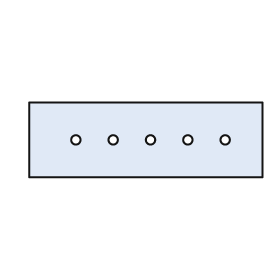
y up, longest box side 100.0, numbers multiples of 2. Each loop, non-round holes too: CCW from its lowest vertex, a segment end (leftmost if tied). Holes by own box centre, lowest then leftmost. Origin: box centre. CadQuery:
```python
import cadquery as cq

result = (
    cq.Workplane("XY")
    .moveTo(-50.0, -16.0)
    .lineTo(50.0, -16.0)
    .lineTo(50.0, 16.0)
    .lineTo(-50.0, 16.0)
    .close()
    .moveTo(-30.0, 0.0)
    .circle(2.0)
    .moveTo(-14.0, 0.0)
    .circle(2.0)
    .moveTo(2.0, 0.0)
    .circle(2.0)
    .moveTo(18.0, 0.0)
    .circle(2.0)
    .moveTo(34.0, 0.0)
    .circle(2.0)
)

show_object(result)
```